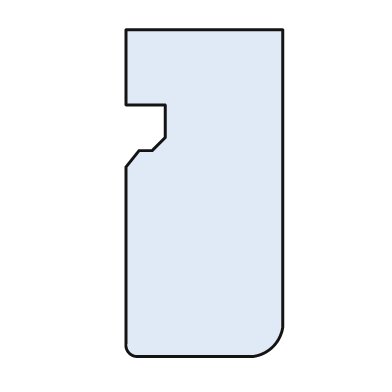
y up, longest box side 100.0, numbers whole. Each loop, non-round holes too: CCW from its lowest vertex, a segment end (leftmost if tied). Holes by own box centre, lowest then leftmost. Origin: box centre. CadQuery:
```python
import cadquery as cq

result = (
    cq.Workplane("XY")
    .moveTo(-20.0, -50.0)
    .lineTo(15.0, -50.0)
    .threePointArc((21.0, -47.0), (24.0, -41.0))
    .lineTo(24.0, 50.0)
    .lineTo(-24.0, 50.0)
    .lineTo(-24.0, 27.0)
    .lineTo(-12.0, 27.0)
    .lineTo(-12.0, 17.0)
    .lineTo(-16.0, 13.0)
    .lineTo(-20.0, 13.0)
    .lineTo(-24.0, 8.0)
    .lineTo(-24.0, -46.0)
    .threePointArc((-23.0, -49.0), (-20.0, -50.0))
    .close()
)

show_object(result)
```